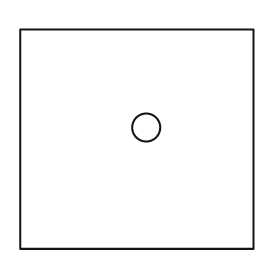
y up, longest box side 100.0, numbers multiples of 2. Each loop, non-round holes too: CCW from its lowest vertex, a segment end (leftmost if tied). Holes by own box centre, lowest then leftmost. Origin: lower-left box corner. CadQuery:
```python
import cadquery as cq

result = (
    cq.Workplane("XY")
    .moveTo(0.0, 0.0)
    .lineTo(100.0, 0.0)
    .lineTo(100.0, 94.0)
    .lineTo(0.0, 94.0)
    .close()
    .moveTo(54.0, 52.0)
    .circle(6.0)
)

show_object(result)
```